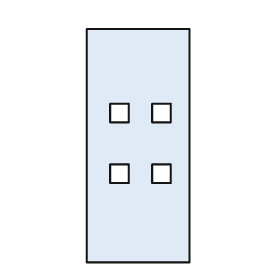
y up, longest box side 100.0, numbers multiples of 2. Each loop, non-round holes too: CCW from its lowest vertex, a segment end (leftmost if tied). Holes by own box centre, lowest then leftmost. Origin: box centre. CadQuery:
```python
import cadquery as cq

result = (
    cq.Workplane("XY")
    .moveTo(-22.0, -50.0)
    .lineTo(22.0, -50.0)
    .lineTo(22.0, 50.0)
    .lineTo(-22.0, 50.0)
    .close()
    .moveTo(-12.0, -16.0)
    .lineTo(-4.0, -16.0)
    .lineTo(-4.0, -8.0)
    .lineTo(-12.0, -8.0)
    .close()
    .moveTo(6.0, -16.0)
    .lineTo(14.0, -16.0)
    .lineTo(14.0, -8.0)
    .lineTo(6.0, -8.0)
    .close()
    .moveTo(-12.0, 10.0)
    .lineTo(-4.0, 10.0)
    .lineTo(-4.0, 18.0)
    .lineTo(-12.0, 18.0)
    .close()
    .moveTo(6.0, 10.0)
    .lineTo(14.0, 10.0)
    .lineTo(14.0, 18.0)
    .lineTo(6.0, 18.0)
    .close()
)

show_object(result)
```